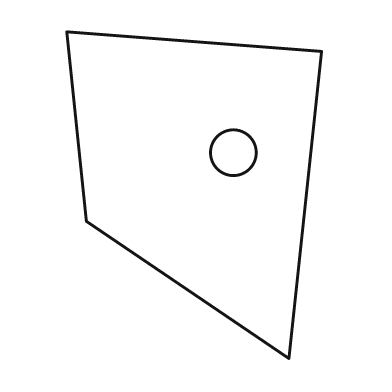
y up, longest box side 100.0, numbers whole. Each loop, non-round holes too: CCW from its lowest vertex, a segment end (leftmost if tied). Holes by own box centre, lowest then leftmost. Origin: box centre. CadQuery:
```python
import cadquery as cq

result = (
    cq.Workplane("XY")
    .moveTo(29.0, -50.0)
    .lineTo(39.0, 44.0)
    .lineTo(-39.0, 50.0)
    .lineTo(-33.0, -8.0)
    .close()
    .moveTo(12.0, 13.0)
    .circle(7.0)
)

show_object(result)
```